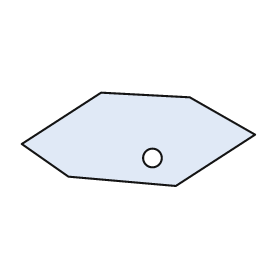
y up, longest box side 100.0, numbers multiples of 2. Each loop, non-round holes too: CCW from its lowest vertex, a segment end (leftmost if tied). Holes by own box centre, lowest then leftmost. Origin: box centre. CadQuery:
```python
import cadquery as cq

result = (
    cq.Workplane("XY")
    .moveTo(16.0, -20.0)
    .lineTo(50.0, 2.0)
    .lineTo(22.0, 18.0)
    .lineTo(-16.0, 20.0)
    .lineTo(-50.0, -2.0)
    .lineTo(-30.0, -16.0)
    .close()
    .moveTo(6.0, -8.0)
    .circle(4.0)
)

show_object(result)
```